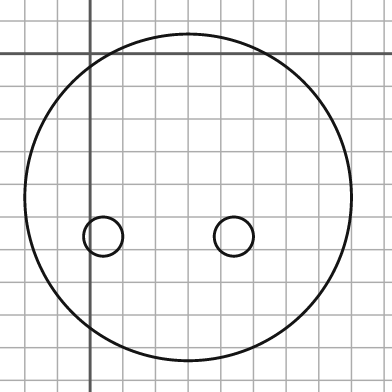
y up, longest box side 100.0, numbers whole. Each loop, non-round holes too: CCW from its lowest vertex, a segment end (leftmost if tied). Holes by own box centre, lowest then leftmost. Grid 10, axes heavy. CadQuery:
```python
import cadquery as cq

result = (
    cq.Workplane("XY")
    .moveTo(30.0, -44.0)
    .circle(50.0)
    .moveTo(4.0, -56.0)
    .circle(6.0)
    .moveTo(44.0, -56.0)
    .circle(6.0)
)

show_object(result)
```